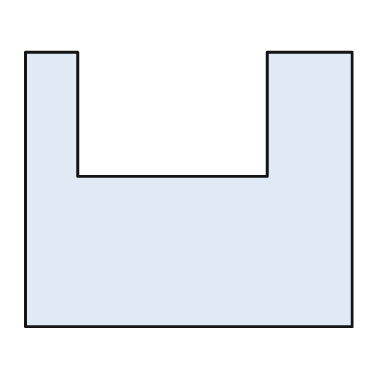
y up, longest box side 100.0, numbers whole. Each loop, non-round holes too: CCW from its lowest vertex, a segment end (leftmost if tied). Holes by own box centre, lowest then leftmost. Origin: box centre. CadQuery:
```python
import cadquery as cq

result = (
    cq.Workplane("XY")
    .moveTo(-50.0, -42.0)
    .lineTo(50.0, -42.0)
    .lineTo(50.0, 42.0)
    .lineTo(24.0, 42.0)
    .lineTo(24.0, 4.0)
    .lineTo(-34.0, 4.0)
    .lineTo(-34.0, 42.0)
    .lineTo(-50.0, 42.0)
    .close()
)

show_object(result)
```